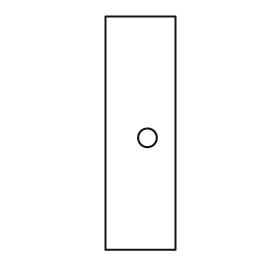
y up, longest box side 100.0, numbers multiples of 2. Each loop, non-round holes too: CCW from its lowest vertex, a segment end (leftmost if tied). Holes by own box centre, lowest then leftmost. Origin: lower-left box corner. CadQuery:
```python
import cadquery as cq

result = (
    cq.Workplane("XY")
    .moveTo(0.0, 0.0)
    .lineTo(30.0, 0.0)
    .lineTo(30.0, 100.0)
    .lineTo(0.0, 100.0)
    .close()
    .moveTo(18.0, 48.0)
    .circle(4.0)
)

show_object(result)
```